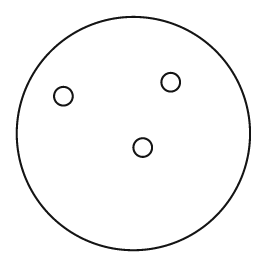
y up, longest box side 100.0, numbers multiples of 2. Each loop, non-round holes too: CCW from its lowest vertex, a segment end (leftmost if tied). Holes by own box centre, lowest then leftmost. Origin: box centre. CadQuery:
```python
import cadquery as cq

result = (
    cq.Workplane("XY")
    .moveTo(0.0, 0.0)
    .circle(50.0)
    .moveTo(4.0, -6.0)
    .circle(4.0)
    .moveTo(-30.0, 16.0)
    .circle(4.0)
    .moveTo(16.0, 22.0)
    .circle(4.0)
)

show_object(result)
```